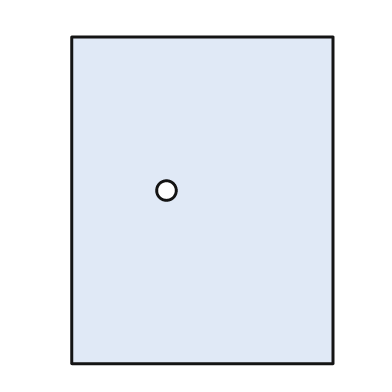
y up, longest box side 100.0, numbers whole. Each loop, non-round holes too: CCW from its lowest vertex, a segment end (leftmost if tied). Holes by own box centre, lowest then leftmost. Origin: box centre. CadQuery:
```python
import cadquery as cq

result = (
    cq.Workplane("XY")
    .moveTo(-40.0, -50.0)
    .lineTo(40.0, -50.0)
    .lineTo(40.0, 50.0)
    .lineTo(-40.0, 50.0)
    .close()
    .moveTo(-11.0, 3.0)
    .circle(3.0)
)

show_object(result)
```